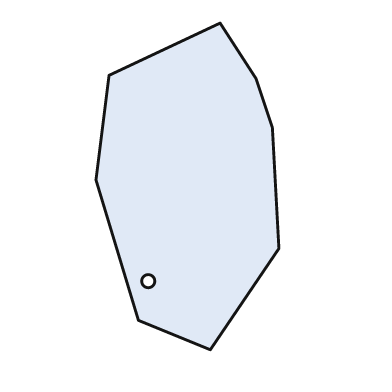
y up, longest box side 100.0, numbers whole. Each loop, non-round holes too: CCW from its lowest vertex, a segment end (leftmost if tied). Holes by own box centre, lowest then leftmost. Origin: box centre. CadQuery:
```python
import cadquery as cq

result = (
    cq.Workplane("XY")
    .moveTo(7.0, -50.0)
    .lineTo(28.0, -19.0)
    .lineTo(26.0, 18.0)
    .lineTo(21.0, 33.0)
    .lineTo(10.0, 50.0)
    .lineTo(-24.0, 34.0)
    .lineTo(-28.0, 2.0)
    .lineTo(-15.0, -41.0)
    .close()
    .moveTo(-12.0, -29.0)
    .circle(2.0)
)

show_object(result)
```